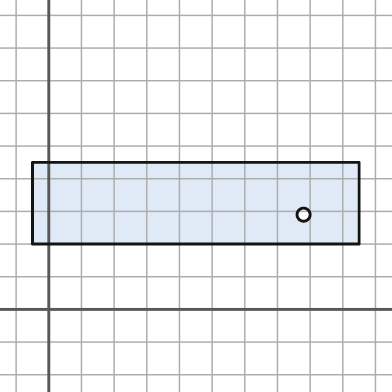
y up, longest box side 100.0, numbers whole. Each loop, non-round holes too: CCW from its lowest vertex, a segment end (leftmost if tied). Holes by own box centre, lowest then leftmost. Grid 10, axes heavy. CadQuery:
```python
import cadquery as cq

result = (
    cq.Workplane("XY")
    .moveTo(-5.0, 20.0)
    .lineTo(95.0, 20.0)
    .lineTo(95.0, 45.0)
    .lineTo(-5.0, 45.0)
    .close()
    .moveTo(78.0, 29.0)
    .circle(2.0)
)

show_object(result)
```